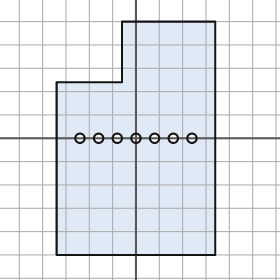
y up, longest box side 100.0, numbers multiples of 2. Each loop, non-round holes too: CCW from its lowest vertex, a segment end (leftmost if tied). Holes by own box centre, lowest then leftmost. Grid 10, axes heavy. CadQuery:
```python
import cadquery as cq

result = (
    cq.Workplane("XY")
    .moveTo(-34.0, -50.0)
    .lineTo(34.0, -50.0)
    .lineTo(34.0, 50.0)
    .lineTo(-6.0, 50.0)
    .lineTo(-6.0, 24.0)
    .lineTo(-34.0, 24.0)
    .close()
    .moveTo(-24.0, 0.0)
    .circle(2.0)
    .moveTo(-16.0, 0.0)
    .circle(2.0)
    .moveTo(-8.0, 0.0)
    .circle(2.0)
    .moveTo(0.0, 0.0)
    .circle(2.0)
    .moveTo(8.0, 0.0)
    .circle(2.0)
    .moveTo(16.0, 0.0)
    .circle(2.0)
    .moveTo(24.0, 0.0)
    .circle(2.0)
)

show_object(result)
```